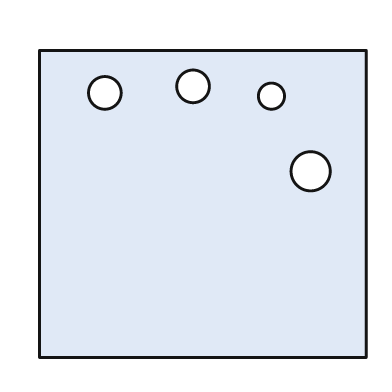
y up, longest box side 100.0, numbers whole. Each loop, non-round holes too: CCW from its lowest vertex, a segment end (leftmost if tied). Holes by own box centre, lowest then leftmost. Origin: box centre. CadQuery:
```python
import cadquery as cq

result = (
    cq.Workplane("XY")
    .moveTo(-50.0, -47.0)
    .lineTo(50.0, -47.0)
    .lineTo(50.0, 47.0)
    .lineTo(-50.0, 47.0)
    .close()
    .moveTo(33.0, 10.0)
    .circle(6.0)
    .moveTo(21.0, 33.0)
    .circle(4.0)
    .moveTo(-30.0, 34.0)
    .circle(5.0)
    .moveTo(-3.0, 36.0)
    .circle(5.0)
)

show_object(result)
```